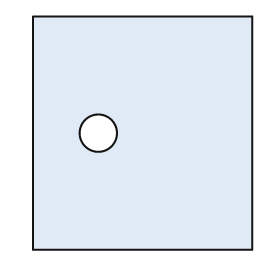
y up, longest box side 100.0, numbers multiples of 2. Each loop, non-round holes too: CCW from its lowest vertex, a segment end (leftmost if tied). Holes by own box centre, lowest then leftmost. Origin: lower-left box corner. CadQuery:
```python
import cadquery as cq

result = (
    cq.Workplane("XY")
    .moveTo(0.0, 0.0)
    .lineTo(94.0, 0.0)
    .lineTo(94.0, 100.0)
    .lineTo(0.0, 100.0)
    .close()
    .moveTo(28.0, 50.0)
    .circle(8.0)
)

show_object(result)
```